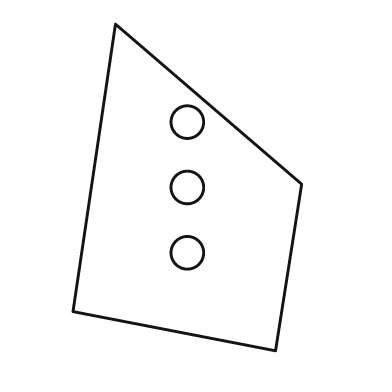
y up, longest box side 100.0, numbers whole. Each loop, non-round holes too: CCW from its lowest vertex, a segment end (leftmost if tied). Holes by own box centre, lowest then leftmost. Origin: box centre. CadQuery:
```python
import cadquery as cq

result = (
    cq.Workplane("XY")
    .moveTo(27.0, -50.0)
    .lineTo(35.0, 1.0)
    .lineTo(-22.0, 50.0)
    .lineTo(-35.0, -38.0)
    .close()
    .moveTo(0.0, -20.0)
    .circle(5.0)
    .moveTo(0.0, 0.0)
    .circle(5.0)
    .moveTo(0.0, 20.0)
    .circle(5.0)
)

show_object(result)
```